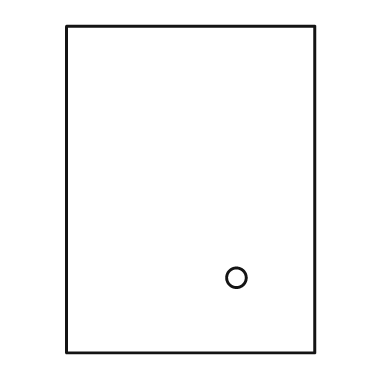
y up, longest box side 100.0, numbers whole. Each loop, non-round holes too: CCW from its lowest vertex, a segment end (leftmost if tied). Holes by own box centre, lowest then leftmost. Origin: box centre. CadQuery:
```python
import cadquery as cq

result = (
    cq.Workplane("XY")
    .moveTo(-38.0, -50.0)
    .lineTo(38.0, -50.0)
    .lineTo(38.0, 50.0)
    .lineTo(-38.0, 50.0)
    .close()
    .moveTo(14.0, -27.0)
    .circle(3.0)
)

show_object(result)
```